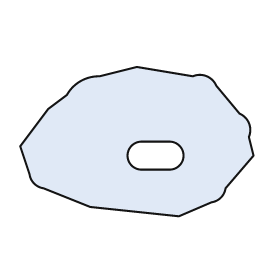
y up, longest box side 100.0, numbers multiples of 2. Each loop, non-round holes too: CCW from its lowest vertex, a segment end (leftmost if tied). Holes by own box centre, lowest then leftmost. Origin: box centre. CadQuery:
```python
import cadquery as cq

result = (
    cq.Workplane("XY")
    .moveTo(18.0, -32.0)
    .lineTo(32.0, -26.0)
    .threePointArc((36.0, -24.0), (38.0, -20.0))
    .lineTo(50.0, -6.0)
    .lineTo(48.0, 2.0)
    .threePointArc((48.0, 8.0), (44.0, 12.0))
    .lineTo(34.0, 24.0)
    .threePointArc((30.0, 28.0), (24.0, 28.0))
    .lineTo(0.0, 32.0)
    .lineTo(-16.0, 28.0)
    .threePointArc((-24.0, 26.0), (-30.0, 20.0))
    .lineTo(-38.0, 14.0)
    .lineTo(-50.0, -2.0)
    .lineTo(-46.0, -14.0)
    .threePointArc((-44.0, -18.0), (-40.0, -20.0))
    .lineTo(-20.0, -28.0)
    .close()
    .moveTo(2.0, -12.0)
    .lineTo(14.0, -12.0)
    .threePointArc((20.0, -6.0), (14.0, 0.0))
    .lineTo(2.0, 0.0)
    .threePointArc((-4.0, -6.0), (2.0, -12.0))
    .close()
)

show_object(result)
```